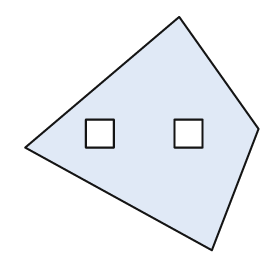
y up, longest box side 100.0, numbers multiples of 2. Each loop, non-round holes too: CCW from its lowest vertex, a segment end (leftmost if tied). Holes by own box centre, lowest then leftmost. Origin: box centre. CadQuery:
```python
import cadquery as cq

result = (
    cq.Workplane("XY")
    .moveTo(30.0, -50.0)
    .lineTo(50.0, 2.0)
    .lineTo(16.0, 50.0)
    .lineTo(-50.0, -6.0)
    .close()
    .moveTo(-24.0, -6.0)
    .lineTo(-12.0, -6.0)
    .lineTo(-12.0, 6.0)
    .lineTo(-24.0, 6.0)
    .close()
    .moveTo(14.0, -6.0)
    .lineTo(26.0, -6.0)
    .lineTo(26.0, 6.0)
    .lineTo(14.0, 6.0)
    .close()
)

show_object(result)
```